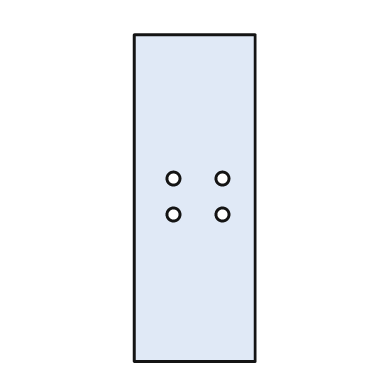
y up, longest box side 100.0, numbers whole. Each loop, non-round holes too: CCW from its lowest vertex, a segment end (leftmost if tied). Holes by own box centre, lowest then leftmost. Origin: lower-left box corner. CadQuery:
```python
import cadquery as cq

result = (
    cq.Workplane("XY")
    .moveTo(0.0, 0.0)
    .lineTo(37.0, 0.0)
    .lineTo(37.0, 100.0)
    .lineTo(0.0, 100.0)
    .close()
    .moveTo(12.0, 45.0)
    .circle(2.0)
    .moveTo(27.0, 45.0)
    .circle(2.0)
    .moveTo(12.0, 56.0)
    .circle(2.0)
    .moveTo(27.0, 56.0)
    .circle(2.0)
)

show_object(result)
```